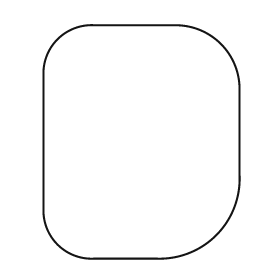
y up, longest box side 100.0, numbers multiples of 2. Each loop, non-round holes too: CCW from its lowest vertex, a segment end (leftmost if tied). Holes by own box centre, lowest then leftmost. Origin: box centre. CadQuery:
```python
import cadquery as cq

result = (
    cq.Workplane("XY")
    .moveTo(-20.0, -50.0)
    .lineTo(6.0, -50.0)
    .threePointArc((32.0, -40.0), (42.0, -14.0))
    .lineTo(42.0, 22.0)
    .threePointArc((34.0, 42.0), (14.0, 50.0))
    .lineTo(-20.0, 50.0)
    .threePointArc((-36.0, 44.0), (-42.0, 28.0))
    .lineTo(-42.0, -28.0)
    .threePointArc((-36.0, -44.0), (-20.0, -50.0))
    .close()
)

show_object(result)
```